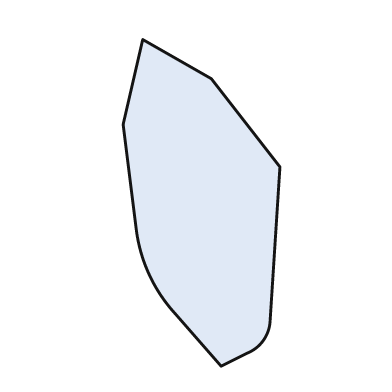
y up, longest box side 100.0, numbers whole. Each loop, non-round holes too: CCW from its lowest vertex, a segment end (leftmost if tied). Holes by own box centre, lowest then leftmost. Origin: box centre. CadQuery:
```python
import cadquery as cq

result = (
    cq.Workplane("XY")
    .moveTo(6.0, -50.0)
    .lineTo(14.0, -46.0)
    .threePointArc((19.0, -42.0), (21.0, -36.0))
    .lineTo(24.0, 11.0)
    .lineTo(3.0, 38.0)
    .lineTo(-18.0, 50.0)
    .lineTo(-24.0, 24.0)
    .lineTo(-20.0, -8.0)
    .threePointArc((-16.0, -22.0), (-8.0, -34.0))
    .close()
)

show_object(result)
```